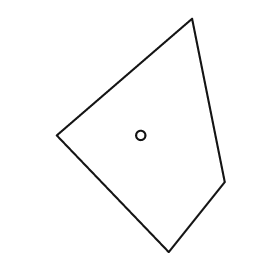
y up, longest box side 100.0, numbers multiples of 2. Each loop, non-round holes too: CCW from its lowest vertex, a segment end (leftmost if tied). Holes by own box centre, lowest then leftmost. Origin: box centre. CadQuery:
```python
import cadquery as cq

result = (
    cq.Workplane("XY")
    .moveTo(12.0, -50.0)
    .lineTo(36.0, -20.0)
    .lineTo(22.0, 50.0)
    .lineTo(-36.0, 0.0)
    .close()
    .moveTo(0.0, 0.0)
    .circle(2.0)
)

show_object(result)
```